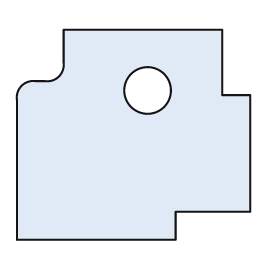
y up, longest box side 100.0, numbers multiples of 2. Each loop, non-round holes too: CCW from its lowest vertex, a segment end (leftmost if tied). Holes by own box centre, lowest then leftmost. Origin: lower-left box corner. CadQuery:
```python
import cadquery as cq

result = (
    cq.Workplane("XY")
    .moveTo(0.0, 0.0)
    .lineTo(68.0, 0.0)
    .lineTo(68.0, 12.0)
    .lineTo(100.0, 12.0)
    .lineTo(100.0, 62.0)
    .lineTo(88.0, 62.0)
    .lineTo(88.0, 90.0)
    .lineTo(20.0, 90.0)
    .lineTo(20.0, 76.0)
    .threePointArc((18.0, 70.0), (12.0, 68.0))
    .lineTo(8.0, 68.0)
    .threePointArc((2.0, 66.0), (0.0, 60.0))
    .close()
    .moveTo(56.0, 64.0)
    .circle(10.0)
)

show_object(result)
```